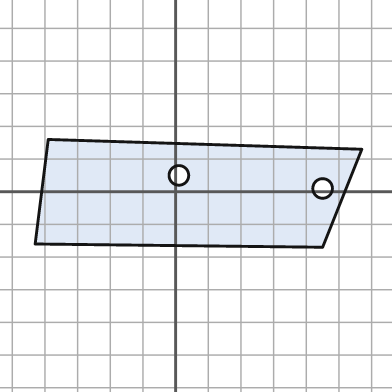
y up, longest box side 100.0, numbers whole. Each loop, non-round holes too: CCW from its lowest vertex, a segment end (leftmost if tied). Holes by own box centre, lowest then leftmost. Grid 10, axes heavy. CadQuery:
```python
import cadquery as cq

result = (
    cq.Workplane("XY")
    .moveTo(45.0, -17.0)
    .lineTo(57.0, 13.0)
    .lineTo(-39.0, 16.0)
    .lineTo(-43.0, -16.0)
    .close()
    .moveTo(45.0, 1.0)
    .circle(3.0)
    .moveTo(1.0, 5.0)
    .circle(3.0)
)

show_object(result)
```